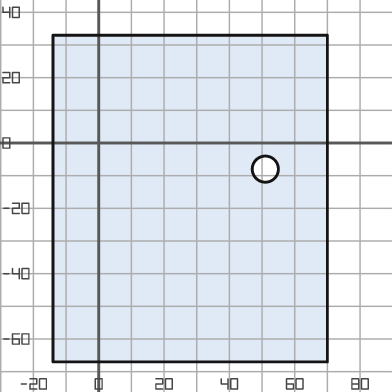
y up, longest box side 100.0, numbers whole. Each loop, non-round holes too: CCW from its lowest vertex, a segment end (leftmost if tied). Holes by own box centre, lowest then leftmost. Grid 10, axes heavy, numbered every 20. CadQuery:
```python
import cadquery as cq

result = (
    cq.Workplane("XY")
    .moveTo(-14.0, -67.0)
    .lineTo(70.0, -67.0)
    .lineTo(70.0, 33.0)
    .lineTo(-14.0, 33.0)
    .close()
    .moveTo(51.0, -8.0)
    .circle(4.0)
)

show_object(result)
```